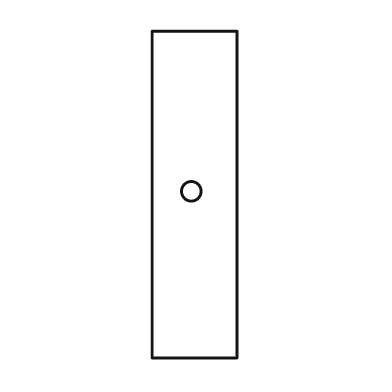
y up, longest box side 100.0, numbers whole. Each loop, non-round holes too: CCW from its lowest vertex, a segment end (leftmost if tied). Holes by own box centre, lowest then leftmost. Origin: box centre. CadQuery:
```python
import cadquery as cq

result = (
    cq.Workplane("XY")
    .moveTo(-13.0, -50.0)
    .lineTo(13.0, -50.0)
    .lineTo(13.0, 50.0)
    .lineTo(-13.0, 50.0)
    .close()
    .moveTo(-1.0, 1.0)
    .circle(3.0)
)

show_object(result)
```